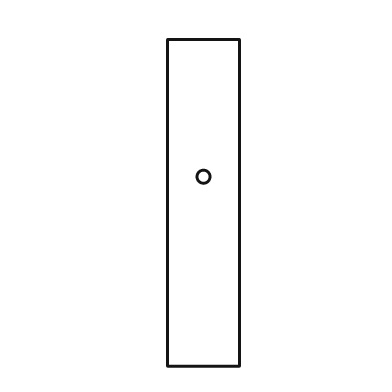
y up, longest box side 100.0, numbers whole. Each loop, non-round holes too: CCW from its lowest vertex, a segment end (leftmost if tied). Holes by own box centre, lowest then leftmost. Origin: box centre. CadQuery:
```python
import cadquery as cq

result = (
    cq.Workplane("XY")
    .moveTo(-11.0, -50.0)
    .lineTo(11.0, -50.0)
    .lineTo(11.0, 50.0)
    .lineTo(-11.0, 50.0)
    .close()
    .moveTo(0.0, 8.0)
    .circle(2.0)
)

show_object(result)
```